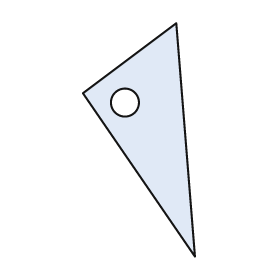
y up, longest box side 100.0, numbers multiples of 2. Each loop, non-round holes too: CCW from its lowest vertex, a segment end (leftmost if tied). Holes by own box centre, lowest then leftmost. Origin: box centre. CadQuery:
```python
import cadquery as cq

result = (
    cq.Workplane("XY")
    .moveTo(24.0, -50.0)
    .lineTo(16.0, 50.0)
    .lineTo(-24.0, 20.0)
    .close()
    .moveTo(-6.0, 16.0)
    .circle(6.0)
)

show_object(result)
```